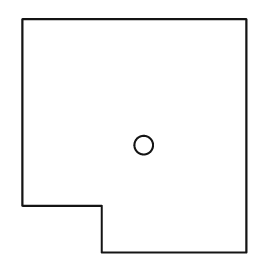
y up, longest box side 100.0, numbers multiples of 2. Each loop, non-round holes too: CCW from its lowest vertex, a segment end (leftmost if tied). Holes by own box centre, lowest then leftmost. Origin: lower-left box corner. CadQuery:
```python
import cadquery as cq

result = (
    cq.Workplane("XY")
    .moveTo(34.0, 0.0)
    .lineTo(96.0, 0.0)
    .lineTo(96.0, 100.0)
    .lineTo(0.0, 100.0)
    .lineTo(0.0, 20.0)
    .lineTo(34.0, 20.0)
    .close()
    .moveTo(52.0, 46.0)
    .circle(4.0)
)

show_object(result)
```